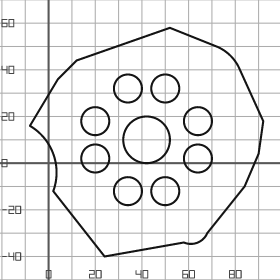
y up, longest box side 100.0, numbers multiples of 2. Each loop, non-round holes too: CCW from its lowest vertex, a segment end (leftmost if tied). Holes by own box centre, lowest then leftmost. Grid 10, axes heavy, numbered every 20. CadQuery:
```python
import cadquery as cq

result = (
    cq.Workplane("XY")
    .moveTo(24.0, -40.0)
    .lineTo(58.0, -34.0)
    .threePointArc((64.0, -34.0), (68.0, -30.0))
    .lineTo(84.0, -10.0)
    .lineTo(90.0, 4.0)
    .lineTo(92.0, 18.0)
    .lineTo(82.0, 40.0)
    .threePointArc((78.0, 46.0), (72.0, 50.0))
    .lineTo(52.0, 58.0)
    .lineTo(12.0, 44.0)
    .lineTo(4.0, 36.0)
    .lineTo(-8.0, 16.0)
    .threePointArc((2.0, 4.0), (2.0, -12.0))
    .close()
    .moveTo(34.0, -12.0)
    .circle(6.0)
    .moveTo(50.0, -12.0)
    .circle(6.0)
    .moveTo(20.0, 2.0)
    .circle(6.0)
    .moveTo(64.0, 2.0)
    .circle(6.0)
    .moveTo(42.0, 10.0)
    .circle(10.0)
    .moveTo(20.0, 18.0)
    .circle(6.0)
    .moveTo(64.0, 18.0)
    .circle(6.0)
    .moveTo(34.0, 32.0)
    .circle(6.0)
    .moveTo(50.0, 32.0)
    .circle(6.0)
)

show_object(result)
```